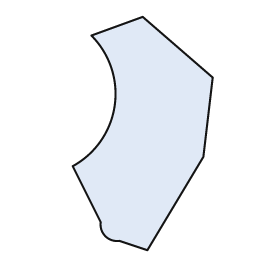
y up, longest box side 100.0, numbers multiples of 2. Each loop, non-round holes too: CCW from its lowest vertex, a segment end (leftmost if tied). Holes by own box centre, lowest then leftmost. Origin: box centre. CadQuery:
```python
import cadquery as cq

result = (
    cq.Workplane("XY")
    .moveTo(2.0, -50.0)
    .lineTo(26.0, -10.0)
    .lineTo(30.0, 24.0)
    .lineTo(0.0, 50.0)
    .lineTo(-22.0, 42.0)
    .threePointArc((-12.0, 12.0), (-30.0, -14.0))
    .lineTo(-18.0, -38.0)
    .threePointArc((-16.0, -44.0), (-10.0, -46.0))
    .close()
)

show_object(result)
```